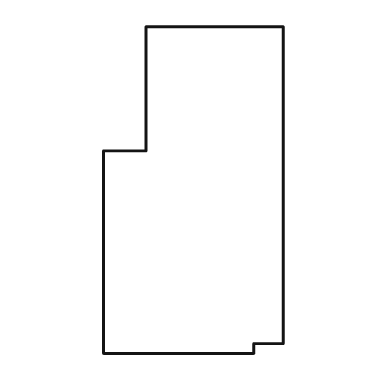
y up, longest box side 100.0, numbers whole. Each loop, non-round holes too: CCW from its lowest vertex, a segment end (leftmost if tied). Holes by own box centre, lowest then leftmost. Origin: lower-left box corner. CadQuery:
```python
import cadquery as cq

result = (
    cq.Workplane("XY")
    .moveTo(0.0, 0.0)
    .lineTo(46.0, 0.0)
    .lineTo(46.0, 3.0)
    .lineTo(55.0, 3.0)
    .lineTo(55.0, 100.0)
    .lineTo(13.0, 100.0)
    .lineTo(13.0, 62.0)
    .lineTo(0.0, 62.0)
    .close()
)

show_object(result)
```